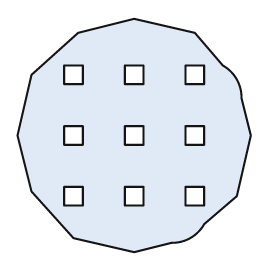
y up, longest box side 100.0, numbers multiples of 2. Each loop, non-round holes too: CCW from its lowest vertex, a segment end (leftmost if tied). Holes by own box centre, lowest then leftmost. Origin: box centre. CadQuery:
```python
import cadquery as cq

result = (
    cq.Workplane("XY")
    .moveTo(0.0, -50.0)
    .lineTo(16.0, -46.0)
    .threePointArc((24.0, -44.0), (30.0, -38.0))
    .lineTo(44.0, -26.0)
    .lineTo(50.0, 0.0)
    .lineTo(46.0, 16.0)
    .threePointArc((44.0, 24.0), (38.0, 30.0))
    .lineTo(26.0, 44.0)
    .lineTo(0.0, 50.0)
    .lineTo(-24.0, 44.0)
    .lineTo(-44.0, 26.0)
    .lineTo(-50.0, 0.0)
    .lineTo(-44.0, -24.0)
    .lineTo(-26.0, -44.0)
    .close()
    .moveTo(-30.0, -30.0)
    .lineTo(-22.0, -30.0)
    .lineTo(-22.0, -22.0)
    .lineTo(-30.0, -22.0)
    .close()
    .moveTo(-4.0, -30.0)
    .lineTo(4.0, -30.0)
    .lineTo(4.0, -22.0)
    .lineTo(-4.0, -22.0)
    .close()
    .moveTo(22.0, -30.0)
    .lineTo(30.0, -30.0)
    .lineTo(30.0, -22.0)
    .lineTo(22.0, -22.0)
    .close()
    .moveTo(-30.0, -4.0)
    .lineTo(-22.0, -4.0)
    .lineTo(-22.0, 4.0)
    .lineTo(-30.0, 4.0)
    .close()
    .moveTo(-4.0, -4.0)
    .lineTo(4.0, -4.0)
    .lineTo(4.0, 4.0)
    .lineTo(-4.0, 4.0)
    .close()
    .moveTo(22.0, -4.0)
    .lineTo(30.0, -4.0)
    .lineTo(30.0, 4.0)
    .lineTo(22.0, 4.0)
    .close()
    .moveTo(-30.0, 22.0)
    .lineTo(-22.0, 22.0)
    .lineTo(-22.0, 30.0)
    .lineTo(-30.0, 30.0)
    .close()
    .moveTo(-4.0, 22.0)
    .lineTo(4.0, 22.0)
    .lineTo(4.0, 30.0)
    .lineTo(-4.0, 30.0)
    .close()
    .moveTo(22.0, 22.0)
    .lineTo(30.0, 22.0)
    .lineTo(30.0, 30.0)
    .lineTo(22.0, 30.0)
    .close()
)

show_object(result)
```